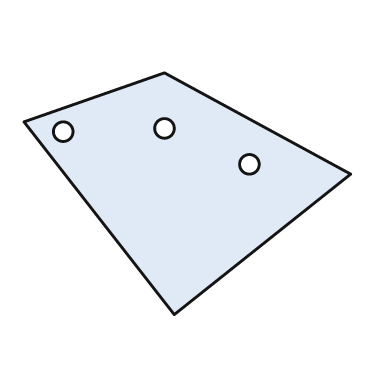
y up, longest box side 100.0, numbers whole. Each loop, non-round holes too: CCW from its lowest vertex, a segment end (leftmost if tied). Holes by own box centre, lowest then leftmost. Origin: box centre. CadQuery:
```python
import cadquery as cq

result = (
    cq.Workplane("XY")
    .moveTo(-4.0, -37.0)
    .lineTo(50.0, 6.0)
    .lineTo(-7.0, 37.0)
    .lineTo(-50.0, 22.0)
    .close()
    .moveTo(19.0, 9.0)
    .circle(3.0)
    .moveTo(-38.0, 19.0)
    .circle(3.0)
    .moveTo(-7.0, 20.0)
    .circle(3.0)
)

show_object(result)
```